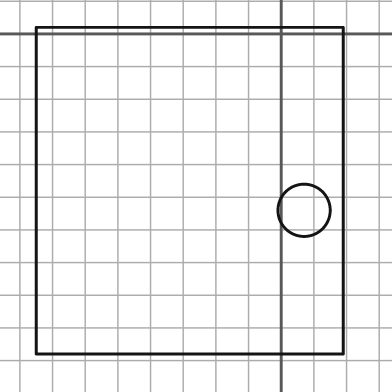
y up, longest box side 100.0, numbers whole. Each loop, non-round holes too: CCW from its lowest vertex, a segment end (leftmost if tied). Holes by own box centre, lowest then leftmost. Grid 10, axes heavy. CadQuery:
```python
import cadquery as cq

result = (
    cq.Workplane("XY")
    .moveTo(-75.0, -98.0)
    .lineTo(19.0, -98.0)
    .lineTo(19.0, 2.0)
    .lineTo(-75.0, 2.0)
    .close()
    .moveTo(7.0, -54.0)
    .circle(8.0)
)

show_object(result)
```